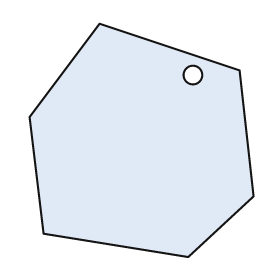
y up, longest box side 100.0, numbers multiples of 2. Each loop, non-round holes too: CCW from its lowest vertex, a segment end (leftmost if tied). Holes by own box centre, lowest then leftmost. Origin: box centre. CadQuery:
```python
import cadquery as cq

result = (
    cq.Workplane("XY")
    .moveTo(20.0, -50.0)
    .lineTo(48.0, -24.0)
    .lineTo(42.0, 30.0)
    .lineTo(-18.0, 50.0)
    .lineTo(-48.0, 10.0)
    .lineTo(-42.0, -40.0)
    .close()
    .moveTo(22.0, 28.0)
    .circle(4.0)
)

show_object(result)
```